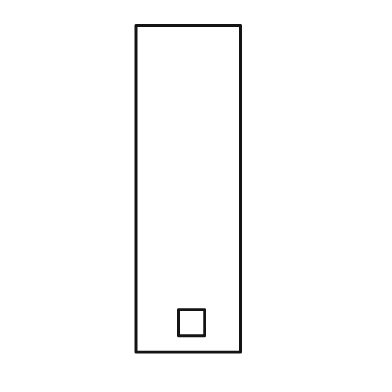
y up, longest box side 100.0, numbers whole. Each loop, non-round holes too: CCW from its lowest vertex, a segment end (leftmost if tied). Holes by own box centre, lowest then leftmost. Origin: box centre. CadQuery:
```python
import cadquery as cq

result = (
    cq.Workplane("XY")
    .moveTo(-16.0, -50.0)
    .lineTo(16.0, -50.0)
    .lineTo(16.0, 50.0)
    .lineTo(-16.0, 50.0)
    .close()
    .moveTo(-3.0, -45.0)
    .lineTo(5.0, -45.0)
    .lineTo(5.0, -37.0)
    .lineTo(-3.0, -37.0)
    .close()
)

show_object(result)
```